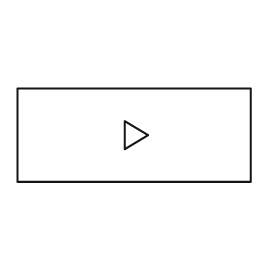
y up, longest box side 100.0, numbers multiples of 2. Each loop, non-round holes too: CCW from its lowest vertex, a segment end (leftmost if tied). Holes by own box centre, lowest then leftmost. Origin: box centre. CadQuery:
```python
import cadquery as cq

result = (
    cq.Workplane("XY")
    .moveTo(-50.0, -20.0)
    .lineTo(50.0, -20.0)
    .lineTo(50.0, 20.0)
    .lineTo(-50.0, 20.0)
    .close()
    .moveTo(-4.0, -6.0)
    .lineTo(6.0, 0.0)
    .lineTo(-4.0, 6.0)
    .close()
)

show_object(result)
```